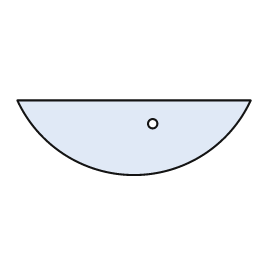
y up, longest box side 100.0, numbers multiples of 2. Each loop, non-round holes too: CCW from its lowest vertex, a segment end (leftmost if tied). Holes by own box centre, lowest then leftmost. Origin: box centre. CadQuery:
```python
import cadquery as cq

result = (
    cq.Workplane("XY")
    .moveTo(-50.0, 16.0)
    .threePointArc((0.0, -16.0), (50.0, 16.0))
    .close()
    .moveTo(8.0, 6.0)
    .circle(2.0)
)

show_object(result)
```